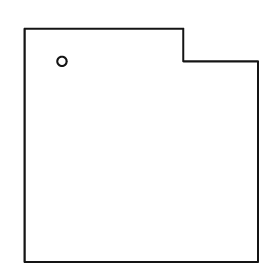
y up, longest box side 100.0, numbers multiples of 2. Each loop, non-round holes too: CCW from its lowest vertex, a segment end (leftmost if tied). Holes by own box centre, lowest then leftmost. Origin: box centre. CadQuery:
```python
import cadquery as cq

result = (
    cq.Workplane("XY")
    .moveTo(-50.0, -50.0)
    .lineTo(50.0, -50.0)
    .lineTo(50.0, 36.0)
    .lineTo(18.0, 36.0)
    .lineTo(18.0, 50.0)
    .lineTo(-50.0, 50.0)
    .close()
    .moveTo(-34.0, 36.0)
    .circle(2.0)
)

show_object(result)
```